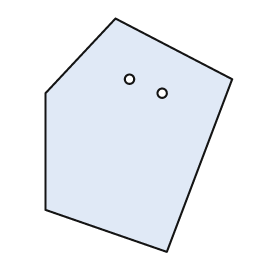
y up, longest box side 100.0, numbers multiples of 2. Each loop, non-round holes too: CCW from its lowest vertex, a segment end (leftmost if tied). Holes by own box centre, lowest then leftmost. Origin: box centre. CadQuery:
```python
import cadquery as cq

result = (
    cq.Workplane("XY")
    .moveTo(12.0, -50.0)
    .lineTo(40.0, 24.0)
    .lineTo(-10.0, 50.0)
    .lineTo(-40.0, 18.0)
    .lineTo(-40.0, -32.0)
    .close()
    .moveTo(10.0, 18.0)
    .circle(2.0)
    .moveTo(-4.0, 24.0)
    .circle(2.0)
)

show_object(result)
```